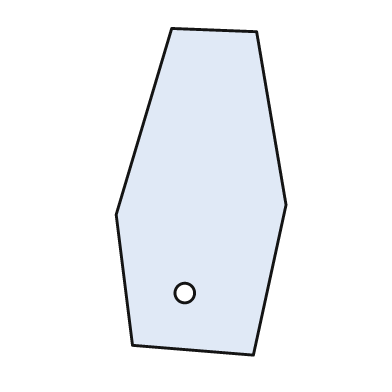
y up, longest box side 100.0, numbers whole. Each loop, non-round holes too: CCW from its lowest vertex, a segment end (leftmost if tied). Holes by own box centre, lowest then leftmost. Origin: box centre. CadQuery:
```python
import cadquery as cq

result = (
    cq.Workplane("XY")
    .moveTo(16.0, -50.0)
    .lineTo(26.0, -4.0)
    .lineTo(17.0, 49.0)
    .lineTo(-9.0, 50.0)
    .lineTo(-26.0, -7.0)
    .lineTo(-21.0, -47.0)
    .close()
    .moveTo(-5.0, -31.0)
    .circle(3.0)
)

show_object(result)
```